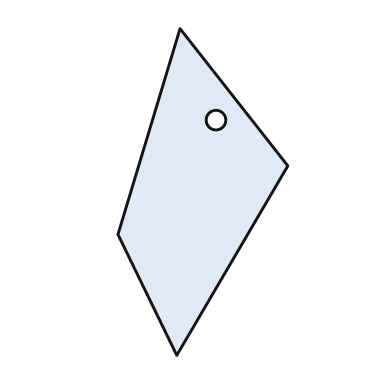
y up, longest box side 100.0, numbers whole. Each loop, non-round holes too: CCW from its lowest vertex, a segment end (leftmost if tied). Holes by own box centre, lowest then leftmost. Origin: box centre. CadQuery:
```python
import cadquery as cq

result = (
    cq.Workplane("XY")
    .moveTo(-8.0, -50.0)
    .lineTo(26.0, 8.0)
    .lineTo(-7.0, 50.0)
    .lineTo(-26.0, -13.0)
    .close()
    .moveTo(4.0, 22.0)
    .circle(3.0)
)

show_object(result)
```